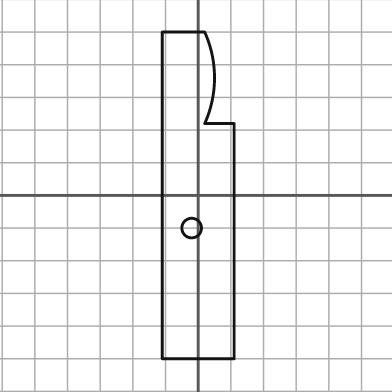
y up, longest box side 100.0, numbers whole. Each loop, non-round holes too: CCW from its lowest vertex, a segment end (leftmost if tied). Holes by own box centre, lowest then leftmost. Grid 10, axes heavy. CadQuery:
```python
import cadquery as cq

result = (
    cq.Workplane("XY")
    .moveTo(-11.0, -50.0)
    .lineTo(11.0, -50.0)
    .lineTo(11.0, 22.0)
    .lineTo(2.0, 22.0)
    .threePointArc((5.0, 36.0), (2.0, 50.0))
    .lineTo(-11.0, 50.0)
    .close()
    .moveTo(-2.0, -10.0)
    .circle(3.0)
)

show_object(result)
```